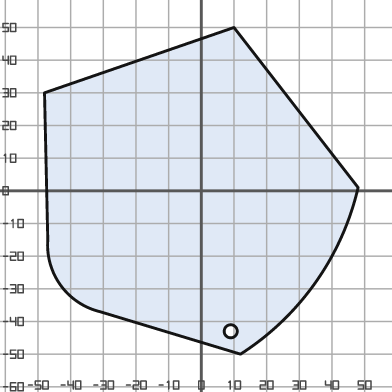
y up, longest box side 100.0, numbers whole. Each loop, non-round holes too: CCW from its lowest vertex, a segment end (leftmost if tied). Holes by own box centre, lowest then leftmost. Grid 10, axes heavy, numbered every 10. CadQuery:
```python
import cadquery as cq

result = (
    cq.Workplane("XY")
    .moveTo(12.0, -50.0)
    .threePointArc((35.0, -28.0), (48.0, 1.0))
    .lineTo(10.0, 50.0)
    .lineTo(-48.0, 30.0)
    .lineTo(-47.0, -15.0)
    .threePointArc((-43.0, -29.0), (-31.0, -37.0))
    .close()
    .moveTo(9.0, -43.0)
    .circle(2.0)
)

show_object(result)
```